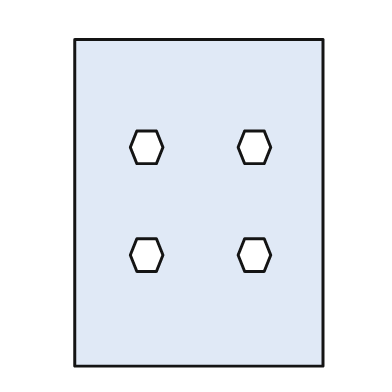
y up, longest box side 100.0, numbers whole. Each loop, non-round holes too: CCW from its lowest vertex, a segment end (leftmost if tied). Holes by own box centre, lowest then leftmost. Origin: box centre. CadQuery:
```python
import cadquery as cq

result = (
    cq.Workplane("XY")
    .moveTo(-38.0, -50.0)
    .lineTo(38.0, -50.0)
    .lineTo(38.0, 50.0)
    .lineTo(-38.0, 50.0)
    .close()
    .moveTo(-19.0, -21.0)
    .lineTo(-13.0, -21.0)
    .lineTo(-11.0, -16.0)
    .lineTo(-13.0, -11.0)
    .lineTo(-19.0, -11.0)
    .lineTo(-21.0, -16.0)
    .close()
    .moveTo(14.0, -21.0)
    .lineTo(20.0, -21.0)
    .lineTo(22.0, -16.0)
    .lineTo(20.0, -11.0)
    .lineTo(14.0, -11.0)
    .lineTo(12.0, -16.0)
    .close()
    .moveTo(-19.0, 12.0)
    .lineTo(-13.0, 12.0)
    .lineTo(-11.0, 17.0)
    .lineTo(-13.0, 22.0)
    .lineTo(-19.0, 22.0)
    .lineTo(-21.0, 17.0)
    .close()
    .moveTo(14.0, 12.0)
    .lineTo(20.0, 12.0)
    .lineTo(22.0, 17.0)
    .lineTo(20.0, 22.0)
    .lineTo(14.0, 22.0)
    .lineTo(12.0, 17.0)
    .close()
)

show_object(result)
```